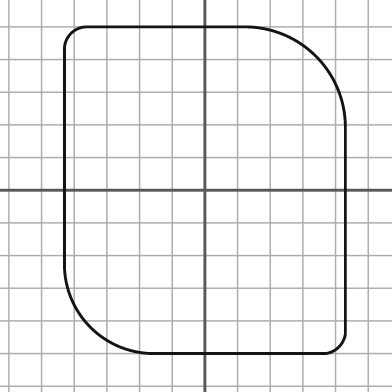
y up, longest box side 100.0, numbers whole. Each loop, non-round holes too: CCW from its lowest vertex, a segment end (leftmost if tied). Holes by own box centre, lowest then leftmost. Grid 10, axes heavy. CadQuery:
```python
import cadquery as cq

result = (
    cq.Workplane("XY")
    .moveTo(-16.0, -50.0)
    .lineTo(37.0, -50.0)
    .threePointArc((41.0, -48.0), (43.0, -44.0))
    .lineTo(43.0, 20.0)
    .threePointArc((34.0, 41.0), (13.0, 50.0))
    .lineTo(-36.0, 50.0)
    .threePointArc((-41.0, 48.0), (-43.0, 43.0))
    .lineTo(-43.0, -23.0)
    .threePointArc((-35.0, -42.0), (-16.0, -50.0))
    .close()
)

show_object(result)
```